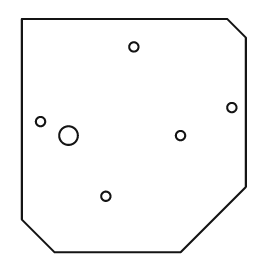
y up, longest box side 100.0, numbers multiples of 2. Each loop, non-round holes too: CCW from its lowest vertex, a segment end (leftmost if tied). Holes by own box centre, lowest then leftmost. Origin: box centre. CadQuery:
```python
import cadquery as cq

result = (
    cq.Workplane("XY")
    .moveTo(-34.0, -50.0)
    .lineTo(20.0, -50.0)
    .lineTo(48.0, -22.0)
    .lineTo(48.0, 42.0)
    .lineTo(40.0, 50.0)
    .lineTo(-48.0, 50.0)
    .lineTo(-48.0, -36.0)
    .close()
    .moveTo(-12.0, -26.0)
    .circle(2.0)
    .moveTo(-28.0, 0.0)
    .circle(4.0)
    .moveTo(20.0, 0.0)
    .circle(2.0)
    .moveTo(-40.0, 6.0)
    .circle(2.0)
    .moveTo(42.0, 12.0)
    .circle(2.0)
    .moveTo(0.0, 38.0)
    .circle(2.0)
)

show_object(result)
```